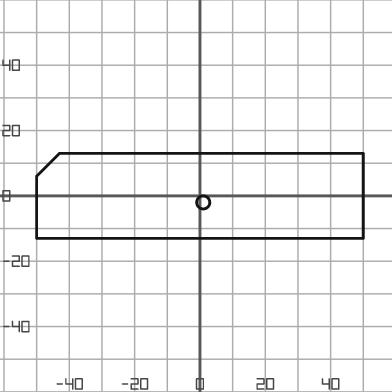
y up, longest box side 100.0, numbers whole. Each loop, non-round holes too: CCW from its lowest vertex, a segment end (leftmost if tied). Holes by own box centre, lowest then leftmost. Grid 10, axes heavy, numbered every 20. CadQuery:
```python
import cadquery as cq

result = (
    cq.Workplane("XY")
    .moveTo(-50.0, -13.0)
    .lineTo(50.0, -13.0)
    .lineTo(50.0, 13.0)
    .lineTo(-43.0, 13.0)
    .lineTo(-50.0, 6.0)
    .close()
    .moveTo(1.0, -2.0)
    .circle(2.0)
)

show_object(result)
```